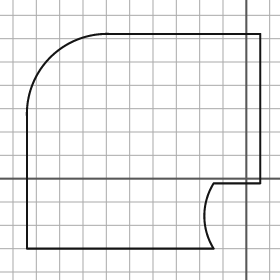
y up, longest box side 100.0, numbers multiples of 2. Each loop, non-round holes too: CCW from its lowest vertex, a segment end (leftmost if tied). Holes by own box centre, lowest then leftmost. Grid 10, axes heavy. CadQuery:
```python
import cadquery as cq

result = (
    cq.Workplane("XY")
    .moveTo(-94.0, -30.0)
    .lineTo(-14.0, -30.0)
    .threePointArc((-18.0, -16.0), (-14.0, -2.0))
    .lineTo(6.0, -2.0)
    .lineTo(6.0, 62.0)
    .lineTo(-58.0, 62.0)
    .threePointArc((-84.0, 52.0), (-94.0, 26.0))
    .close()
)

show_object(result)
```